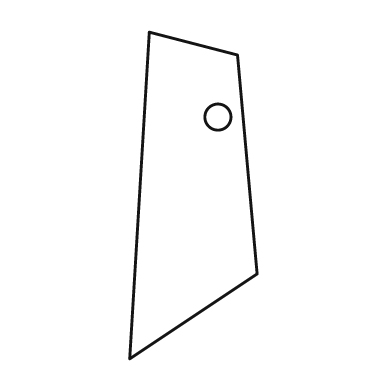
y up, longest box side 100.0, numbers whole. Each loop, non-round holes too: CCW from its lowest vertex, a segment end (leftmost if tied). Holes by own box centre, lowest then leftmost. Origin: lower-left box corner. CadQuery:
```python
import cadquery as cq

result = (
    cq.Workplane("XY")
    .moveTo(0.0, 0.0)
    .lineTo(39.0, 26.0)
    .lineTo(33.0, 93.0)
    .lineTo(6.0, 100.0)
    .close()
    .moveTo(27.0, 74.0)
    .circle(4.0)
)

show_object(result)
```